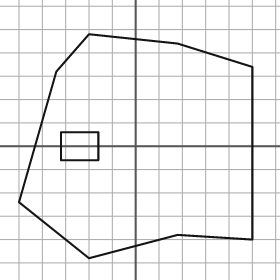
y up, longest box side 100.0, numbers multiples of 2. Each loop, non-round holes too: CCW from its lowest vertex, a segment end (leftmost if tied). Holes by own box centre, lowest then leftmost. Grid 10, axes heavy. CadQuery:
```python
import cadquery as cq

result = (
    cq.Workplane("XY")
    .moveTo(-20.0, -48.0)
    .lineTo(18.0, -38.0)
    .lineTo(50.0, -40.0)
    .lineTo(50.0, 34.0)
    .lineTo(18.0, 44.0)
    .lineTo(-20.0, 48.0)
    .lineTo(-34.0, 32.0)
    .lineTo(-50.0, -24.0)
    .close()
    .moveTo(-32.0, -6.0)
    .lineTo(-16.0, -6.0)
    .lineTo(-16.0, 6.0)
    .lineTo(-32.0, 6.0)
    .close()
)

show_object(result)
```